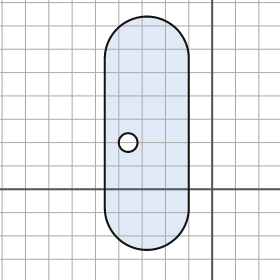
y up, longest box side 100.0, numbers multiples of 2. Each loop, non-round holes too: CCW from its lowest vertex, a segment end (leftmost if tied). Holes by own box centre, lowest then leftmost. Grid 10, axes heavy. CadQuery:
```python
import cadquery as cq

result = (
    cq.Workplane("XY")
    .moveTo(-46.0, -8.0)
    .threePointArc((-28.0, -26.0), (-10.0, -8.0))
    .lineTo(-10.0, 56.0)
    .threePointArc((-28.0, 74.0), (-46.0, 56.0))
    .close()
    .moveTo(-36.0, 20.0)
    .circle(4.0)
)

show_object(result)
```